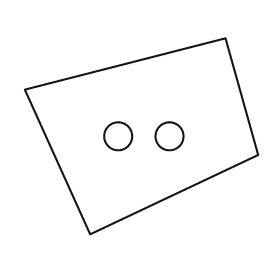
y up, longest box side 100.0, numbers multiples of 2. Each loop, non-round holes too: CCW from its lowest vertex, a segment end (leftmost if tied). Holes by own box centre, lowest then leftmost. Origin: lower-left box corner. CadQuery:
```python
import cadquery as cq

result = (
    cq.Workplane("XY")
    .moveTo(28.0, 0.0)
    .lineTo(100.0, 34.0)
    .lineTo(86.0, 84.0)
    .lineTo(0.0, 62.0)
    .close()
    .moveTo(40.0, 42.0)
    .circle(6.0)
    .moveTo(62.0, 42.0)
    .circle(6.0)
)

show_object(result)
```